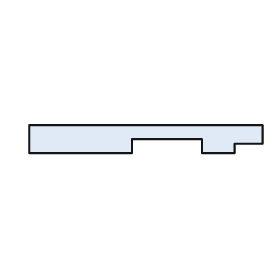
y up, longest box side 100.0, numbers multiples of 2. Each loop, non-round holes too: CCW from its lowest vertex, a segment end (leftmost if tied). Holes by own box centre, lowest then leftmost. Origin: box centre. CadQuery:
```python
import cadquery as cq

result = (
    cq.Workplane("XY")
    .moveTo(-50.0, -6.0)
    .lineTo(-6.0, -6.0)
    .lineTo(-6.0, 0.0)
    .lineTo(24.0, 0.0)
    .lineTo(24.0, -6.0)
    .lineTo(38.0, -6.0)
    .lineTo(38.0, -2.0)
    .lineTo(50.0, -2.0)
    .lineTo(50.0, 6.0)
    .lineTo(-50.0, 6.0)
    .close()
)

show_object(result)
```